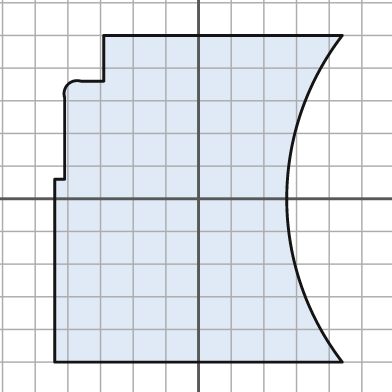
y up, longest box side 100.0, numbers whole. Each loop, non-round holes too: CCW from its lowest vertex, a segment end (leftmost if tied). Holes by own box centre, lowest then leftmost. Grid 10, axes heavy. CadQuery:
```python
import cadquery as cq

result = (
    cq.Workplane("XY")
    .moveTo(-44.0, -50.0)
    .lineTo(44.0, -50.0)
    .threePointArc((27.0, 0.0), (44.0, 50.0))
    .lineTo(-29.0, 50.0)
    .lineTo(-29.0, 36.0)
    .lineTo(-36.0, 36.0)
    .threePointArc((-40.0, 35.0), (-41.0, 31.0))
    .lineTo(-41.0, 6.0)
    .lineTo(-44.0, 6.0)
    .close()
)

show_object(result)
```